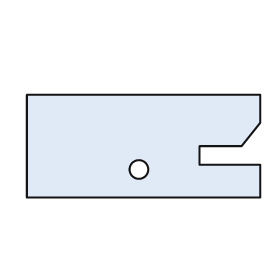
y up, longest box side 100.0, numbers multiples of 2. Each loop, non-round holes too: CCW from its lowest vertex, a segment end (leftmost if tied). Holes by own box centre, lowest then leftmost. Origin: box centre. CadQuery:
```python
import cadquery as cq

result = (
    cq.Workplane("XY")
    .moveTo(-50.0, -22.0)
    .lineTo(50.0, -22.0)
    .lineTo(50.0, -8.0)
    .lineTo(24.0, -8.0)
    .lineTo(24.0, 0.0)
    .lineTo(42.0, 0.0)
    .lineTo(50.0, 10.0)
    .lineTo(50.0, 22.0)
    .lineTo(-50.0, 22.0)
    .close()
    .moveTo(-2.0, -10.0)
    .circle(4.0)
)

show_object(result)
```